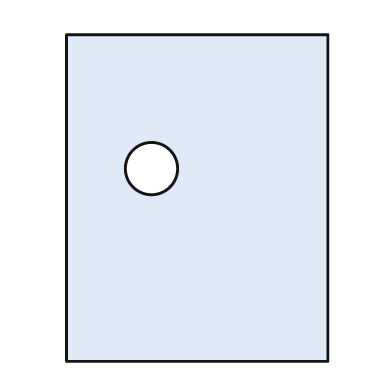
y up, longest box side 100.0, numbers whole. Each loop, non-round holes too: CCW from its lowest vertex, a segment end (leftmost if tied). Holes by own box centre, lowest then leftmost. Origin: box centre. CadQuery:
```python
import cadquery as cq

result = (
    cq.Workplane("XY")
    .moveTo(-40.0, -50.0)
    .lineTo(40.0, -50.0)
    .lineTo(40.0, 50.0)
    .lineTo(-40.0, 50.0)
    .close()
    .moveTo(-14.0, 9.0)
    .circle(8.0)
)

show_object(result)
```